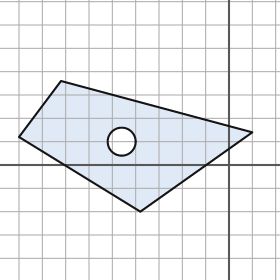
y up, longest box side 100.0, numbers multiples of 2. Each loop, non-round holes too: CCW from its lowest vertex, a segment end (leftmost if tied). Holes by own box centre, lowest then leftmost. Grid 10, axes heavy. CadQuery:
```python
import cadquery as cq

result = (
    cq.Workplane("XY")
    .moveTo(-38.0, -20.0)
    .lineTo(10.0, 14.0)
    .lineTo(-72.0, 36.0)
    .lineTo(-90.0, 12.0)
    .close()
    .moveTo(-46.0, 10.0)
    .circle(6.0)
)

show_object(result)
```